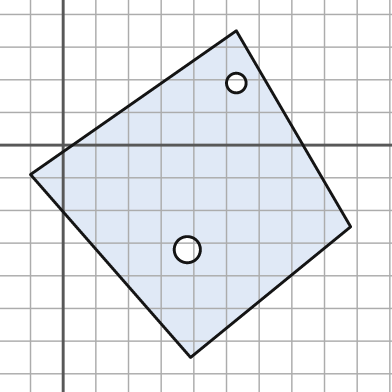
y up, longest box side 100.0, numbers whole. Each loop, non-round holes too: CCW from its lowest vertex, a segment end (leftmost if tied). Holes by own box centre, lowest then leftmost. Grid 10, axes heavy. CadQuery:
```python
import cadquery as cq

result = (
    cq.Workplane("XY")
    .moveTo(39.0, -65.0)
    .lineTo(88.0, -25.0)
    .lineTo(53.0, 35.0)
    .lineTo(-10.0, -9.0)
    .close()
    .moveTo(38.0, -32.0)
    .circle(4.0)
    .moveTo(53.0, 19.0)
    .circle(3.0)
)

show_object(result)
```